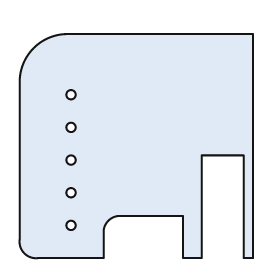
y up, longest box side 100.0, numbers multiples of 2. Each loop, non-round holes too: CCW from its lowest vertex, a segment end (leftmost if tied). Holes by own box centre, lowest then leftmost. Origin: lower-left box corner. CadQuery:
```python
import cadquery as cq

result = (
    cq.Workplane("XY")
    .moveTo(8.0, 0.0)
    .lineTo(36.0, 0.0)
    .lineTo(36.0, 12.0)
    .threePointArc((38.0, 16.0), (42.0, 18.0))
    .lineTo(70.0, 18.0)
    .lineTo(70.0, 0.0)
    .lineTo(78.0, 0.0)
    .lineTo(78.0, 44.0)
    .lineTo(96.0, 44.0)
    .lineTo(96.0, 0.0)
    .lineTo(100.0, 0.0)
    .lineTo(100.0, 96.0)
    .lineTo(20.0, 96.0)
    .threePointArc((6.0, 90.0), (0.0, 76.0))
    .lineTo(0.0, 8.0)
    .threePointArc((2.0, 2.0), (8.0, 0.0))
    .close()
    .moveTo(22.0, 14.0)
    .circle(2.0)
    .moveTo(22.0, 28.0)
    .circle(2.0)
    .moveTo(22.0, 42.0)
    .circle(2.0)
    .moveTo(22.0, 56.0)
    .circle(2.0)
    .moveTo(22.0, 70.0)
    .circle(2.0)
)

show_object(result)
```